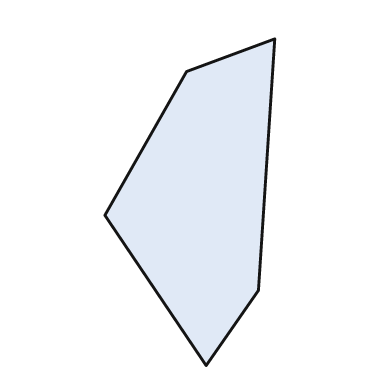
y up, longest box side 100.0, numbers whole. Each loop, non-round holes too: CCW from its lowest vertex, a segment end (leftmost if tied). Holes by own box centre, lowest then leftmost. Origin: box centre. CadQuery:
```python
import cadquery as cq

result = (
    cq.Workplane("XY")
    .moveTo(5.0, -50.0)
    .lineTo(21.0, -27.0)
    .lineTo(26.0, 50.0)
    .lineTo(-1.0, 40.0)
    .lineTo(-26.0, -4.0)
    .close()
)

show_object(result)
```